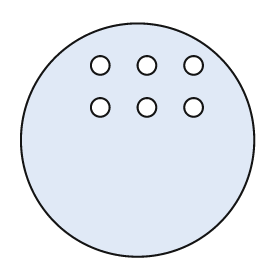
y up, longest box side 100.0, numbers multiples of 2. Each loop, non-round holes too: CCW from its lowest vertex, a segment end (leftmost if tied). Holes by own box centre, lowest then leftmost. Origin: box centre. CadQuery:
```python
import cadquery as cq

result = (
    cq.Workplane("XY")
    .moveTo(0.0, 0.0)
    .circle(50.0)
    .moveTo(-16.0, 14.0)
    .circle(4.0)
    .moveTo(4.0, 14.0)
    .circle(4.0)
    .moveTo(24.0, 14.0)
    .circle(4.0)
    .moveTo(-16.0, 32.0)
    .circle(4.0)
    .moveTo(4.0, 32.0)
    .circle(4.0)
    .moveTo(24.0, 32.0)
    .circle(4.0)
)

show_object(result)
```